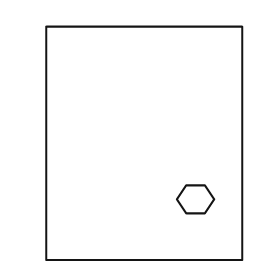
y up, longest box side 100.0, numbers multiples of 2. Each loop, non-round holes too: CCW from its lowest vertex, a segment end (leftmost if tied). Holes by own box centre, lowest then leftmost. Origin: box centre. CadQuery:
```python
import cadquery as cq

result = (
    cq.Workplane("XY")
    .moveTo(-42.0, -50.0)
    .lineTo(42.0, -50.0)
    .lineTo(42.0, 50.0)
    .lineTo(-42.0, 50.0)
    .close()
    .moveTo(18.0, -30.0)
    .lineTo(26.0, -30.0)
    .lineTo(30.0, -24.0)
    .lineTo(26.0, -18.0)
    .lineTo(18.0, -18.0)
    .lineTo(14.0, -24.0)
    .close()
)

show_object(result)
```